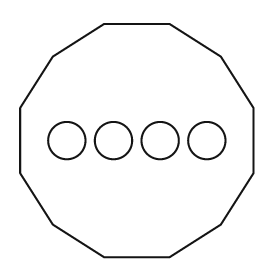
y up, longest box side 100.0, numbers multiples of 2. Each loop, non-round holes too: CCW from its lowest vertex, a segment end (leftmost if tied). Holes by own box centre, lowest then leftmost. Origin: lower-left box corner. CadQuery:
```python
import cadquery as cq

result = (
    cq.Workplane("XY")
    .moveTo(36.0, 0.0)
    .lineTo(64.0, 0.0)
    .lineTo(86.0, 14.0)
    .lineTo(100.0, 36.0)
    .lineTo(100.0, 64.0)
    .lineTo(86.0, 86.0)
    .lineTo(64.0, 100.0)
    .lineTo(36.0, 100.0)
    .lineTo(14.0, 86.0)
    .lineTo(0.0, 64.0)
    .lineTo(0.0, 36.0)
    .lineTo(14.0, 14.0)
    .close()
    .moveTo(20.0, 50.0)
    .circle(8.0)
    .moveTo(40.0, 50.0)
    .circle(8.0)
    .moveTo(60.0, 50.0)
    .circle(8.0)
    .moveTo(80.0, 50.0)
    .circle(8.0)
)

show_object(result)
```